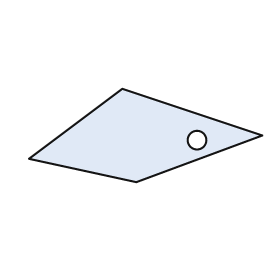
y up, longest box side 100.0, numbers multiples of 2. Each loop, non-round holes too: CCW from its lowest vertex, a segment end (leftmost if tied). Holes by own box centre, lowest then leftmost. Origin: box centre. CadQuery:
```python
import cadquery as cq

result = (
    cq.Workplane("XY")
    .moveTo(-4.0, -20.0)
    .lineTo(50.0, 0.0)
    .lineTo(-10.0, 20.0)
    .lineTo(-50.0, -10.0)
    .close()
    .moveTo(22.0, -2.0)
    .circle(4.0)
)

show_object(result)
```